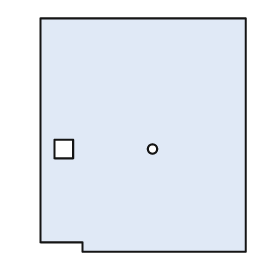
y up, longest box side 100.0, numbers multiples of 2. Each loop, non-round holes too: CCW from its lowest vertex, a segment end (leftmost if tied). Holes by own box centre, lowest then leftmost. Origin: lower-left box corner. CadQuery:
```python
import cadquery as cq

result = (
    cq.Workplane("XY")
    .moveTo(18.0, 0.0)
    .lineTo(88.0, 0.0)
    .lineTo(88.0, 100.0)
    .lineTo(0.0, 100.0)
    .lineTo(0.0, 4.0)
    .lineTo(18.0, 4.0)
    .close()
    .moveTo(6.0, 40.0)
    .lineTo(14.0, 40.0)
    .lineTo(14.0, 48.0)
    .lineTo(6.0, 48.0)
    .close()
    .moveTo(48.0, 44.0)
    .circle(2.0)
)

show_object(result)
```